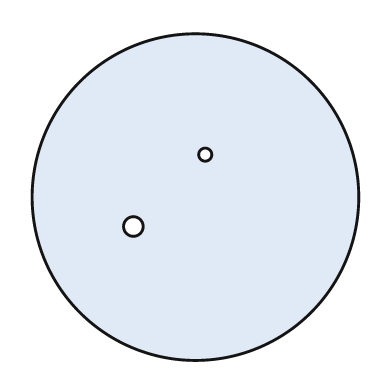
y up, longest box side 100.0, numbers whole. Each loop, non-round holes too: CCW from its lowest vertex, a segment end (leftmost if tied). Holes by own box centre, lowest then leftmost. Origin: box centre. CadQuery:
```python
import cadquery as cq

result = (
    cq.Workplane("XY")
    .moveTo(0.0, 0.0)
    .circle(50.0)
    .moveTo(-19.0, -9.0)
    .circle(3.0)
    .moveTo(3.0, 13.0)
    .circle(2.0)
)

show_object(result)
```